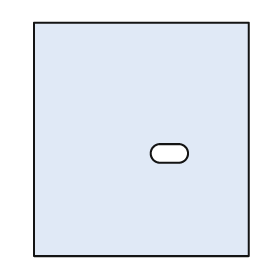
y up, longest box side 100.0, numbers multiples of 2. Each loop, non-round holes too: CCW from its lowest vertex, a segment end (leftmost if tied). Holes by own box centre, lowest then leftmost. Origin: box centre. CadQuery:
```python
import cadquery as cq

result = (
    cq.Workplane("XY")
    .moveTo(-46.0, -50.0)
    .lineTo(46.0, -50.0)
    .lineTo(46.0, 50.0)
    .lineTo(-46.0, 50.0)
    .close()
    .moveTo(8.0, -10.0)
    .lineTo(16.0, -10.0)
    .threePointArc((20.0, -6.0), (16.0, -2.0))
    .lineTo(8.0, -2.0)
    .threePointArc((4.0, -6.0), (8.0, -10.0))
    .close()
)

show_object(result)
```